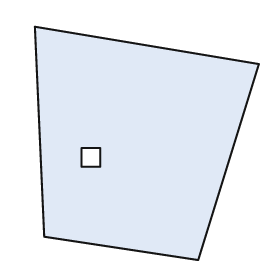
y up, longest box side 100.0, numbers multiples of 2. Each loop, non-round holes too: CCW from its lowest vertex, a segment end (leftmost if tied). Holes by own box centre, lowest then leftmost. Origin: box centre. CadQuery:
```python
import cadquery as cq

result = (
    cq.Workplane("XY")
    .moveTo(22.0, -50.0)
    .lineTo(48.0, 34.0)
    .lineTo(-48.0, 50.0)
    .lineTo(-44.0, -40.0)
    .close()
    .moveTo(-28.0, -10.0)
    .lineTo(-20.0, -10.0)
    .lineTo(-20.0, -2.0)
    .lineTo(-28.0, -2.0)
    .close()
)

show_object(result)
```